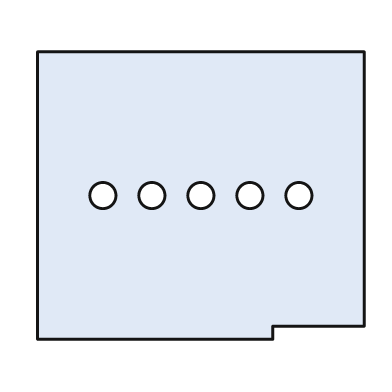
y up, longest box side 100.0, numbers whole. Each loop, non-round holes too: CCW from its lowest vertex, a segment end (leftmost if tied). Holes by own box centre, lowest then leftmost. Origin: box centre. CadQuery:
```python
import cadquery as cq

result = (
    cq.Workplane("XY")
    .moveTo(-50.0, -44.0)
    .lineTo(22.0, -44.0)
    .lineTo(22.0, -40.0)
    .lineTo(50.0, -40.0)
    .lineTo(50.0, 44.0)
    .lineTo(-50.0, 44.0)
    .close()
    .moveTo(-30.0, 0.0)
    .circle(4.0)
    .moveTo(-15.0, 0.0)
    .circle(4.0)
    .moveTo(0.0, 0.0)
    .circle(4.0)
    .moveTo(15.0, 0.0)
    .circle(4.0)
    .moveTo(30.0, 0.0)
    .circle(4.0)
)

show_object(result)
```